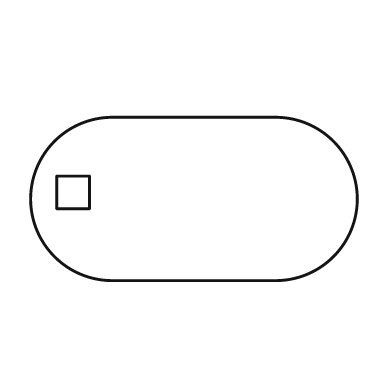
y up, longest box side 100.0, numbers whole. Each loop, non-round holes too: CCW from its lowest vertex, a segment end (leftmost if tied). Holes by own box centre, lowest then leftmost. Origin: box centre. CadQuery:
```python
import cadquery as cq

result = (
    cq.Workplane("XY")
    .moveTo(-25.0, -25.0)
    .lineTo(25.0, -25.0)
    .threePointArc((50.0, 0.0), (25.0, 25.0))
    .lineTo(-25.0, 25.0)
    .threePointArc((-50.0, 0.0), (-25.0, -25.0))
    .close()
    .moveTo(-42.0, -3.0)
    .lineTo(-32.0, -3.0)
    .lineTo(-32.0, 7.0)
    .lineTo(-42.0, 7.0)
    .close()
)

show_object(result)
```